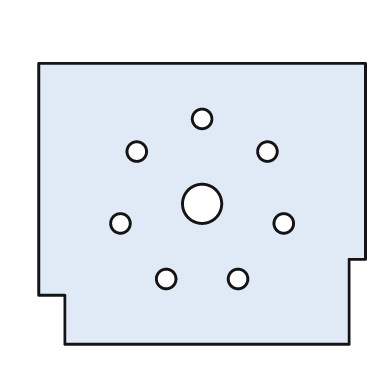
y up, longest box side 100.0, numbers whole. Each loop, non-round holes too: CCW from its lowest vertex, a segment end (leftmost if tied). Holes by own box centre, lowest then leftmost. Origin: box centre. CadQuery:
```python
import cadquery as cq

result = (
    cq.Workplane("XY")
    .moveTo(-42.0, -43.0)
    .lineTo(45.0, -43.0)
    .lineTo(45.0, -17.0)
    .lineTo(50.0, -17.0)
    .lineTo(50.0, 43.0)
    .lineTo(-50.0, 43.0)
    .lineTo(-50.0, -28.0)
    .lineTo(-42.0, -28.0)
    .close()
    .moveTo(-11.0, -23.0)
    .circle(3.0)
    .moveTo(11.0, -23.0)
    .circle(3.0)
    .moveTo(-25.0, -6.0)
    .circle(3.0)
    .moveTo(25.0, -6.0)
    .circle(3.0)
    .moveTo(0.0, 0.0)
    .circle(6.0)
    .moveTo(-20.0, 16.0)
    .circle(3.0)
    .moveTo(20.0, 16.0)
    .circle(3.0)
    .moveTo(0.0, 26.0)
    .circle(3.0)
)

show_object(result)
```